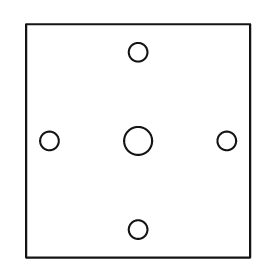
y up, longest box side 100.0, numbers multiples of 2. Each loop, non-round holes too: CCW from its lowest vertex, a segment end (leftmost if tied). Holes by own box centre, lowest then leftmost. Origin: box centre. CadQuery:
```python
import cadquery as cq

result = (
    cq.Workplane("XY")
    .moveTo(-48.0, -50.0)
    .lineTo(48.0, -50.0)
    .lineTo(48.0, 50.0)
    .lineTo(-48.0, 50.0)
    .close()
    .moveTo(0.0, -38.0)
    .circle(4.0)
    .moveTo(-38.0, 0.0)
    .circle(4.0)
    .moveTo(0.0, 0.0)
    .circle(6.0)
    .moveTo(38.0, 0.0)
    .circle(4.0)
    .moveTo(0.0, 38.0)
    .circle(4.0)
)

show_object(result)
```